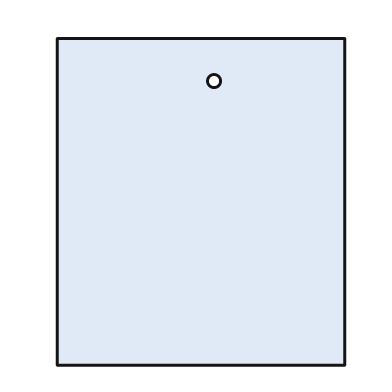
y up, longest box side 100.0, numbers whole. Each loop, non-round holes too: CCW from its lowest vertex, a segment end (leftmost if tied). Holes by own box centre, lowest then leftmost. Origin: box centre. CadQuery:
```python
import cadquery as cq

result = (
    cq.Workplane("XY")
    .moveTo(-44.0, -50.0)
    .lineTo(44.0, -50.0)
    .lineTo(44.0, 50.0)
    .lineTo(-44.0, 50.0)
    .close()
    .moveTo(4.0, 37.0)
    .circle(2.0)
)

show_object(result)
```